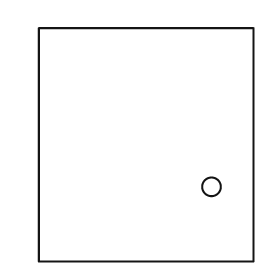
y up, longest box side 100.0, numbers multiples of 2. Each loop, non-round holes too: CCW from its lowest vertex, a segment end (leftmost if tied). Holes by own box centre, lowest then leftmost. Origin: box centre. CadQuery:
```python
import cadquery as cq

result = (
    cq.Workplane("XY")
    .moveTo(-46.0, -50.0)
    .lineTo(46.0, -50.0)
    .lineTo(46.0, 50.0)
    .lineTo(-46.0, 50.0)
    .close()
    .moveTo(28.0, -18.0)
    .circle(4.0)
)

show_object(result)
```